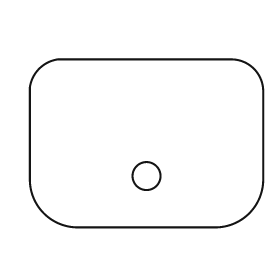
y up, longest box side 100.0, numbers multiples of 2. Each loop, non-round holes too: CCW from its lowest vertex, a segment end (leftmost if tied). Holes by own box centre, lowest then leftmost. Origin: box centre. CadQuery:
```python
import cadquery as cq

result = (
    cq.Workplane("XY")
    .moveTo(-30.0, -36.0)
    .lineTo(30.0, -36.0)
    .threePointArc((44.0, -30.0), (50.0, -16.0))
    .lineTo(50.0, 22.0)
    .threePointArc((46.0, 32.0), (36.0, 36.0))
    .lineTo(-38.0, 36.0)
    .threePointArc((-46.0, 32.0), (-50.0, 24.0))
    .lineTo(-50.0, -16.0)
    .threePointArc((-44.0, -30.0), (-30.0, -36.0))
    .close()
    .moveTo(0.0, -14.0)
    .circle(6.0)
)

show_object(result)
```